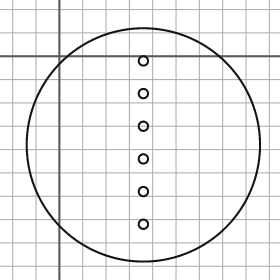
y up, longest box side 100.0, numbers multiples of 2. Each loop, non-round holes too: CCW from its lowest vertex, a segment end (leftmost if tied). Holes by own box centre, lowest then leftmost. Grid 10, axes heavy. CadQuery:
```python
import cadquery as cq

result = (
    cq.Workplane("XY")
    .moveTo(36.0, -38.0)
    .circle(50.0)
    .moveTo(36.0, -72.0)
    .circle(2.0)
    .moveTo(36.0, -58.0)
    .circle(2.0)
    .moveTo(36.0, -44.0)
    .circle(2.0)
    .moveTo(36.0, -30.0)
    .circle(2.0)
    .moveTo(36.0, -16.0)
    .circle(2.0)
    .moveTo(36.0, -2.0)
    .circle(2.0)
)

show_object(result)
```